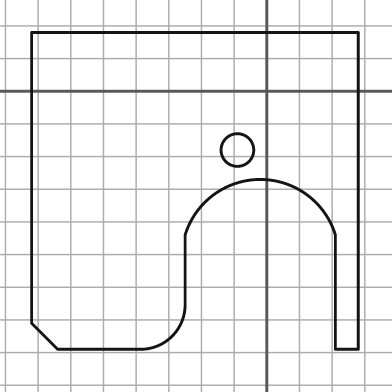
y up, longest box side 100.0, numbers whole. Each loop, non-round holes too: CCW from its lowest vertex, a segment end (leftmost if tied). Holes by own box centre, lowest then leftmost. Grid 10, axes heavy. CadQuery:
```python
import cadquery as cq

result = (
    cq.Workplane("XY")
    .moveTo(-64.0, -79.0)
    .lineTo(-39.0, -79.0)
    .threePointArc((-29.0, -75.0), (-25.0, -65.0))
    .lineTo(-25.0, -44.0)
    .threePointArc((-2.0, -27.0), (21.0, -44.0))
    .lineTo(21.0, -79.0)
    .lineTo(28.0, -79.0)
    .lineTo(28.0, 18.0)
    .lineTo(-72.0, 18.0)
    .lineTo(-72.0, -71.0)
    .close()
    .moveTo(-9.0, -18.0)
    .circle(5.0)
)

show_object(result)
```